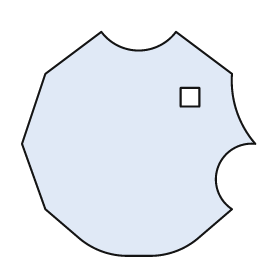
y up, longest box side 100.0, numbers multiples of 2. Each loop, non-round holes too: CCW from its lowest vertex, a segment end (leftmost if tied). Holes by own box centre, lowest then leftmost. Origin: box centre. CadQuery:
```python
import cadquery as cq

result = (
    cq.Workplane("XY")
    .moveTo(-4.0, -48.0)
    .lineTo(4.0, -48.0)
    .threePointArc((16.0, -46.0), (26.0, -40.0))
    .lineTo(40.0, -28.0)
    .threePointArc((34.0, -10.0), (50.0, 0.0))
    .threePointArc((42.0, 14.0), (40.0, 30.0))
    .lineTo(16.0, 48.0)
    .threePointArc((0.0, 40.0), (-16.0, 48.0))
    .lineTo(-40.0, 30.0)
    .lineTo(-50.0, 0.0)
    .lineTo(-40.0, -28.0)
    .lineTo(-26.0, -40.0)
    .threePointArc((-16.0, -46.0), (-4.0, -48.0))
    .close()
    .moveTo(18.0, 16.0)
    .lineTo(26.0, 16.0)
    .lineTo(26.0, 24.0)
    .lineTo(18.0, 24.0)
    .close()
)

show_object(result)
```